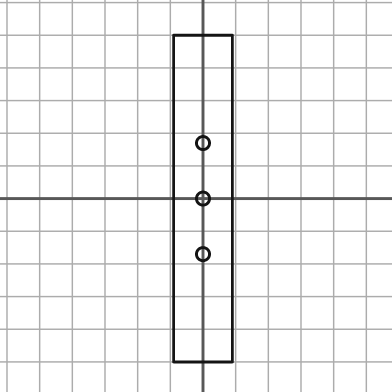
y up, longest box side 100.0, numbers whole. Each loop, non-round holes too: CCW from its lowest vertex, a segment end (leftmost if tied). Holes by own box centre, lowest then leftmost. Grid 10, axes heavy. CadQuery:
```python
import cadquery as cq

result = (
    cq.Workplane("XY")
    .moveTo(-9.0, -50.0)
    .lineTo(9.0, -50.0)
    .lineTo(9.0, 50.0)
    .lineTo(-9.0, 50.0)
    .close()
    .moveTo(0.0, -17.0)
    .circle(2.0)
    .moveTo(0.0, 0.0)
    .circle(2.0)
    .moveTo(0.0, 17.0)
    .circle(2.0)
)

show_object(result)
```